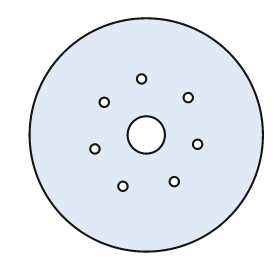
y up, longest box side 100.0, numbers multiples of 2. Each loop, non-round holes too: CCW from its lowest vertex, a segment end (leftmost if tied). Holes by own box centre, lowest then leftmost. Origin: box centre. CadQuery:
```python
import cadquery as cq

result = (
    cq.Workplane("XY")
    .moveTo(0.0, 0.0)
    .circle(50.0)
    .moveTo(-10.0, -22.0)
    .circle(2.0)
    .moveTo(12.0, -20.0)
    .circle(2.0)
    .moveTo(-22.0, -6.0)
    .circle(2.0)
    .moveTo(22.0, -4.0)
    .circle(2.0)
    .moveTo(0.0, 0.0)
    .circle(8.0)
    .moveTo(-18.0, 14.0)
    .circle(2.0)
    .moveTo(18.0, 16.0)
    .circle(2.0)
    .moveTo(-2.0, 24.0)
    .circle(2.0)
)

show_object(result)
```